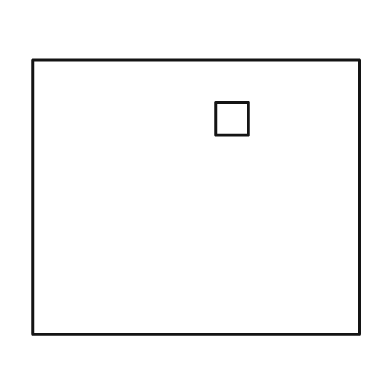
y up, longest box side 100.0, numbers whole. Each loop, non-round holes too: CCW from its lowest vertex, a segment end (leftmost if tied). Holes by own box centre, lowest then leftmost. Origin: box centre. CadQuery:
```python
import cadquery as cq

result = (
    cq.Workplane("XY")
    .moveTo(-50.0, -42.0)
    .lineTo(50.0, -42.0)
    .lineTo(50.0, 42.0)
    .lineTo(-50.0, 42.0)
    .close()
    .moveTo(6.0, 19.0)
    .lineTo(16.0, 19.0)
    .lineTo(16.0, 29.0)
    .lineTo(6.0, 29.0)
    .close()
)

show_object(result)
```